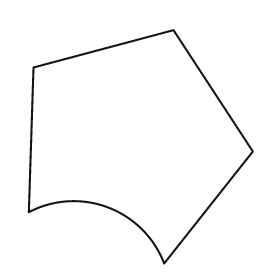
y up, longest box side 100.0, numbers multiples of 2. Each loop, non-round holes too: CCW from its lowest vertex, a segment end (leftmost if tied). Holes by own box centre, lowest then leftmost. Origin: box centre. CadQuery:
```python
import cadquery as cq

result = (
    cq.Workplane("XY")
    .moveTo(10.0, -50.0)
    .lineTo(48.0, -2.0)
    .lineTo(14.0, 50.0)
    .lineTo(-46.0, 34.0)
    .lineTo(-48.0, -28.0)
    .threePointArc((-14.0, -26.0), (10.0, -50.0))
    .close()
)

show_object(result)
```